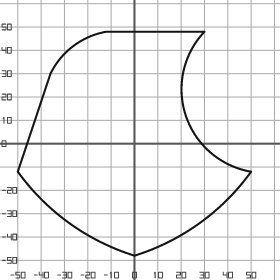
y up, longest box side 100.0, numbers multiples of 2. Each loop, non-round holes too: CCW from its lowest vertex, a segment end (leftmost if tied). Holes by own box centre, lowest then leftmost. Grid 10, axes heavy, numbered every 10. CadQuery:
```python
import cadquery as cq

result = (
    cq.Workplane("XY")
    .moveTo(0.0, -48.0)
    .threePointArc((28.0, -34.0), (50.0, -12.0))
    .threePointArc((22.0, 12.0), (30.0, 48.0))
    .lineTo(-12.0, 48.0)
    .threePointArc((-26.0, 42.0), (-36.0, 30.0))
    .lineTo(-50.0, -12.0)
    .threePointArc((-28.0, -34.0), (0.0, -48.0))
    .close()
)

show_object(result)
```